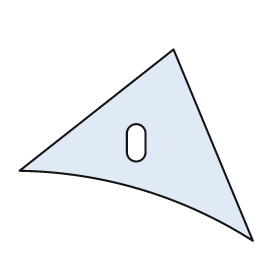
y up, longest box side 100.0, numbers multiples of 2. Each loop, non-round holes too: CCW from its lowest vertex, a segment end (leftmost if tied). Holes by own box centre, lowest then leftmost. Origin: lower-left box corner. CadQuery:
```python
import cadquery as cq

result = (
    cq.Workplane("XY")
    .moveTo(100.0, 0.0)
    .lineTo(66.0, 82.0)
    .lineTo(0.0, 30.0)
    .threePointArc((52.0, 22.0), (100.0, 0.0))
    .close()
    .moveTo(46.0, 38.0)
    .threePointArc((50.0, 34.0), (54.0, 38.0))
    .lineTo(54.0, 46.0)
    .threePointArc((50.0, 50.0), (46.0, 46.0))
    .close()
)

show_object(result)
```